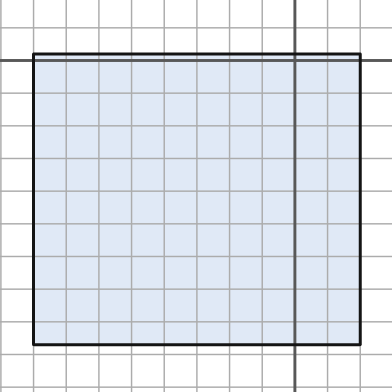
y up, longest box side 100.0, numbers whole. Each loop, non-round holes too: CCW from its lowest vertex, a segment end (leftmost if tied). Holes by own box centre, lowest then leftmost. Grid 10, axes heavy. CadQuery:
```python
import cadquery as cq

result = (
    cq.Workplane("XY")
    .moveTo(-80.0, -87.0)
    .lineTo(20.0, -87.0)
    .lineTo(20.0, 2.0)
    .lineTo(-80.0, 2.0)
    .close()
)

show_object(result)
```